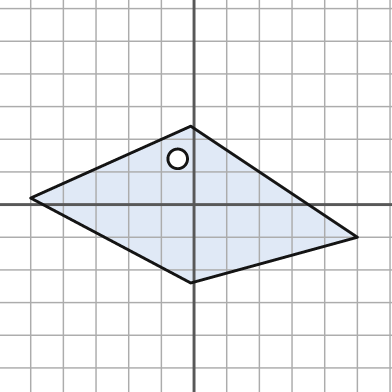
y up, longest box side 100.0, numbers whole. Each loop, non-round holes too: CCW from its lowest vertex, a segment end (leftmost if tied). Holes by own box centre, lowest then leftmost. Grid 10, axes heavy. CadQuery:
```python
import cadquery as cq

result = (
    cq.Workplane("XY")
    .moveTo(-1.0, -24.0)
    .lineTo(50.0, -10.0)
    .lineTo(-1.0, 24.0)
    .lineTo(-50.0, 2.0)
    .close()
    .moveTo(-5.0, 14.0)
    .circle(3.0)
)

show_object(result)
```